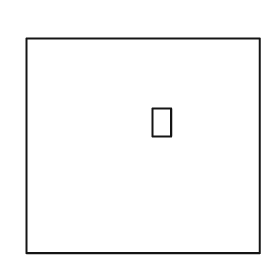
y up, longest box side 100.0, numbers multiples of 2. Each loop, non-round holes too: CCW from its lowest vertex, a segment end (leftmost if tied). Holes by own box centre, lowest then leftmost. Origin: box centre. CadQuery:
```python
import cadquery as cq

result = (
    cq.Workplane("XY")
    .moveTo(-50.0, -46.0)
    .lineTo(50.0, -46.0)
    .lineTo(50.0, 46.0)
    .lineTo(-50.0, 46.0)
    .close()
    .moveTo(4.0, 4.0)
    .lineTo(12.0, 4.0)
    .lineTo(12.0, 16.0)
    .lineTo(4.0, 16.0)
    .close()
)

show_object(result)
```